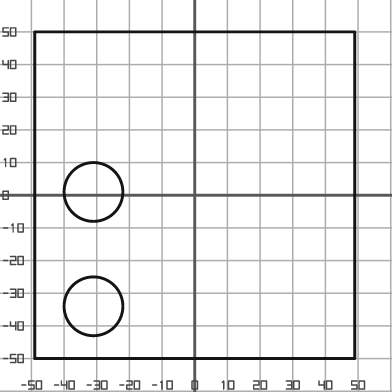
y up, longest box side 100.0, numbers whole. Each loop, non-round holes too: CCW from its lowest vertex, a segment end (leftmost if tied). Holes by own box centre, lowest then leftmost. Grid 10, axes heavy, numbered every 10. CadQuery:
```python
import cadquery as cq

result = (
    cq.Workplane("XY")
    .moveTo(-49.0, -50.0)
    .lineTo(49.0, -50.0)
    .lineTo(49.0, 50.0)
    .lineTo(-49.0, 50.0)
    .close()
    .moveTo(-31.0, -34.0)
    .circle(9.0)
    .moveTo(-31.0, 1.0)
    .circle(9.0)
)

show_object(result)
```